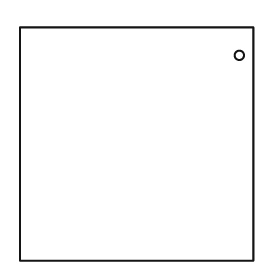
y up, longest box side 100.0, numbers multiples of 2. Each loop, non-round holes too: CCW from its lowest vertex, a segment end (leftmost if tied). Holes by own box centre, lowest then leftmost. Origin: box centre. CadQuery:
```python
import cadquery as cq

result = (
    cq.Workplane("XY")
    .moveTo(-50.0, -50.0)
    .lineTo(50.0, -50.0)
    .lineTo(50.0, 50.0)
    .lineTo(-50.0, 50.0)
    .close()
    .moveTo(44.0, 38.0)
    .circle(2.0)
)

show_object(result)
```